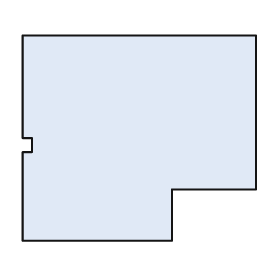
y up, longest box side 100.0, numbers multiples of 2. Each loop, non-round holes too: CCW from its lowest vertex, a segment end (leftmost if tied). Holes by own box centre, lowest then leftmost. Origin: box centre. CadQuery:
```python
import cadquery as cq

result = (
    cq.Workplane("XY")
    .moveTo(-50.0, -44.0)
    .lineTo(14.0, -44.0)
    .lineTo(14.0, -22.0)
    .lineTo(50.0, -22.0)
    .lineTo(50.0, 44.0)
    .lineTo(-50.0, 44.0)
    .lineTo(-50.0, 0.0)
    .lineTo(-46.0, 0.0)
    .lineTo(-46.0, -6.0)
    .lineTo(-50.0, -6.0)
    .close()
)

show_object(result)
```